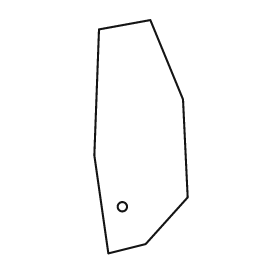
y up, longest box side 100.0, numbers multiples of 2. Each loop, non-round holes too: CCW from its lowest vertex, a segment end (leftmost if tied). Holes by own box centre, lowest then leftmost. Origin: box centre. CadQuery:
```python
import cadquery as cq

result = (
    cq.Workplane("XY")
    .moveTo(-14.0, -50.0)
    .lineTo(2.0, -46.0)
    .lineTo(20.0, -26.0)
    .lineTo(18.0, 16.0)
    .lineTo(4.0, 50.0)
    .lineTo(-18.0, 46.0)
    .lineTo(-20.0, -8.0)
    .close()
    .moveTo(-8.0, -30.0)
    .circle(2.0)
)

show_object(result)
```